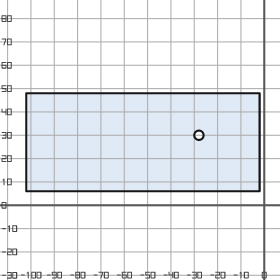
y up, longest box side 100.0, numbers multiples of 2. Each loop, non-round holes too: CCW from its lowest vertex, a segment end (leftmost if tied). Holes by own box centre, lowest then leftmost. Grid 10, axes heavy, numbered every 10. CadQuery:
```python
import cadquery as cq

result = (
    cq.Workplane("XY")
    .moveTo(-102.0, 6.0)
    .lineTo(-2.0, 6.0)
    .lineTo(-2.0, 48.0)
    .lineTo(-102.0, 48.0)
    .close()
    .moveTo(-28.0, 30.0)
    .circle(2.0)
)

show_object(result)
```